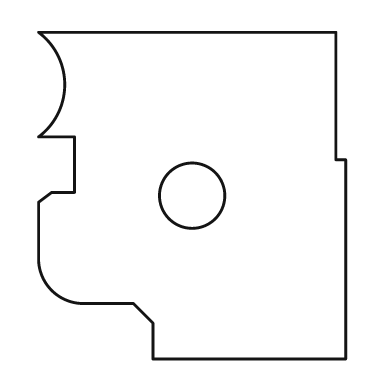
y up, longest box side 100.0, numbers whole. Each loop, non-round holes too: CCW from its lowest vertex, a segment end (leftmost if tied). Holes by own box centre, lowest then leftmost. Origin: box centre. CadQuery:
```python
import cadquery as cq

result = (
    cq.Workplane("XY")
    .moveTo(-12.0, -50.0)
    .lineTo(47.0, -50.0)
    .lineTo(47.0, 11.0)
    .lineTo(44.0, 11.0)
    .lineTo(44.0, 50.0)
    .lineTo(-47.0, 50.0)
    .threePointArc((-39.0, 34.0), (-47.0, 18.0))
    .lineTo(-36.0, 18.0)
    .lineTo(-36.0, 1.0)
    .lineTo(-43.0, 1.0)
    .lineTo(-47.0, -2.0)
    .lineTo(-47.0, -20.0)
    .threePointArc((-43.0, -29.0), (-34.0, -33.0))
    .lineTo(-18.0, -33.0)
    .lineTo(-12.0, -39.0)
    .close()
    .moveTo(0.0, 0.0)
    .circle(10.0)
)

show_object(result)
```